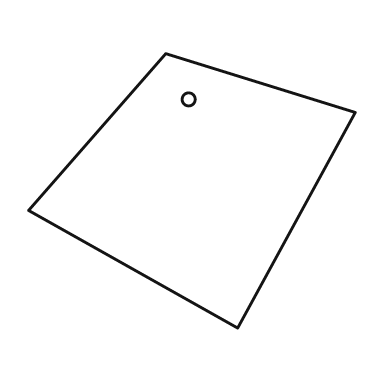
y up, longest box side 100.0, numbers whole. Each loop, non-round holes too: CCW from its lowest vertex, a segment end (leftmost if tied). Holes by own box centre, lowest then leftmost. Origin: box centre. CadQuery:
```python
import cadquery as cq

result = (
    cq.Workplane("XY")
    .moveTo(14.0, -42.0)
    .lineTo(50.0, 24.0)
    .lineTo(-8.0, 42.0)
    .lineTo(-50.0, -6.0)
    .close()
    .moveTo(-1.0, 28.0)
    .circle(2.0)
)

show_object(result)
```